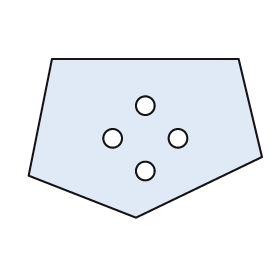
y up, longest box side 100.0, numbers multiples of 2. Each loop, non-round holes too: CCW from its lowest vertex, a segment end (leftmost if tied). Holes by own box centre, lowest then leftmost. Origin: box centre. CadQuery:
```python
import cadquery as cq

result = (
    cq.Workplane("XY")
    .moveTo(-4.0, -34.0)
    .lineTo(50.0, -8.0)
    .lineTo(40.0, 34.0)
    .lineTo(-40.0, 34.0)
    .lineTo(-50.0, -16.0)
    .close()
    .moveTo(0.0, -14.0)
    .circle(4.0)
    .moveTo(-14.0, 0.0)
    .circle(4.0)
    .moveTo(14.0, 0.0)
    .circle(4.0)
    .moveTo(0.0, 14.0)
    .circle(4.0)
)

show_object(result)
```